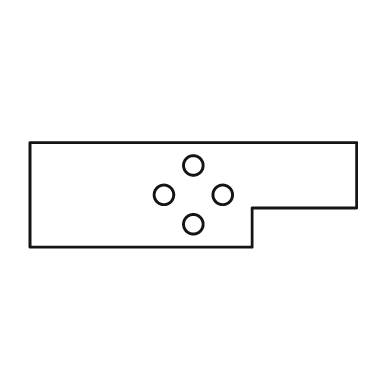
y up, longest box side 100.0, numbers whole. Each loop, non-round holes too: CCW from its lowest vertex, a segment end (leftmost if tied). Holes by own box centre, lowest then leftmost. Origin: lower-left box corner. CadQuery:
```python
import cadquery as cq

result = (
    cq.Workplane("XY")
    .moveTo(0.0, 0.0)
    .lineTo(68.0, 0.0)
    .lineTo(68.0, 12.0)
    .lineTo(100.0, 12.0)
    .lineTo(100.0, 32.0)
    .lineTo(0.0, 32.0)
    .close()
    .moveTo(50.0, 7.0)
    .circle(3.0)
    .moveTo(41.0, 16.0)
    .circle(3.0)
    .moveTo(59.0, 16.0)
    .circle(3.0)
    .moveTo(50.0, 25.0)
    .circle(3.0)
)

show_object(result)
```